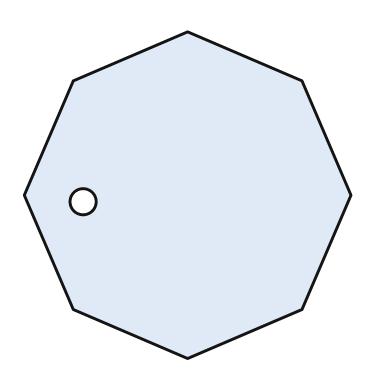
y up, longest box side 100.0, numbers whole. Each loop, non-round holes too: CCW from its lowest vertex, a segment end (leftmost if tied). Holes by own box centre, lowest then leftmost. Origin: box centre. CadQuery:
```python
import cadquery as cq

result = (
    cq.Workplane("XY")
    .moveTo(0.0, -50.0)
    .lineTo(35.0, -35.0)
    .lineTo(50.0, 0.0)
    .lineTo(35.0, 35.0)
    .lineTo(0.0, 50.0)
    .lineTo(-35.0, 35.0)
    .lineTo(-50.0, 0.0)
    .lineTo(-35.0, -35.0)
    .close()
    .moveTo(-32.0, -2.0)
    .circle(4.0)
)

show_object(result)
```